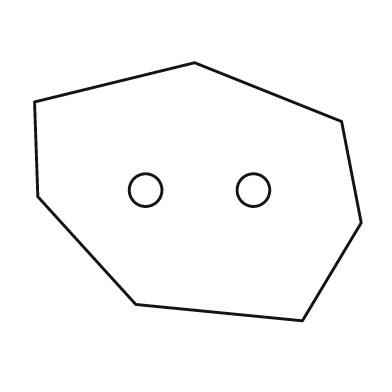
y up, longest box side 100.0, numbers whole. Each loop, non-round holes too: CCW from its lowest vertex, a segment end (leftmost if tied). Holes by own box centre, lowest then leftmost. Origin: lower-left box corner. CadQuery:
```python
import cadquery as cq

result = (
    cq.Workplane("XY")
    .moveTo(82.0, 0.0)
    .lineTo(100.0, 30.0)
    .lineTo(94.0, 61.0)
    .lineTo(49.0, 79.0)
    .lineTo(0.0, 67.0)
    .lineTo(1.0, 38.0)
    .lineTo(31.0, 5.0)
    .close()
    .moveTo(34.0, 40.0)
    .circle(5.0)
    .moveTo(67.0, 40.0)
    .circle(5.0)
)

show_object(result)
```